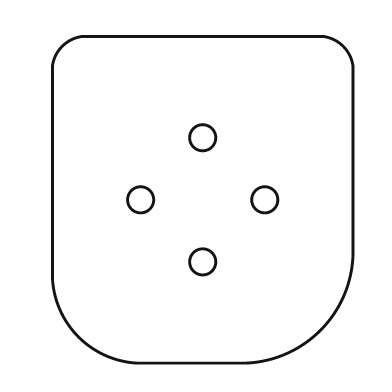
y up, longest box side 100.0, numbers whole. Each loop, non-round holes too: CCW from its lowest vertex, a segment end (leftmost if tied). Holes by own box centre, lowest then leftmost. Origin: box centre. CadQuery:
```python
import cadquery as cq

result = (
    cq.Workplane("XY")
    .moveTo(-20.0, -50.0)
    .lineTo(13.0, -50.0)
    .threePointArc((36.0, -40.0), (46.0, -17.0))
    .lineTo(46.0, 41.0)
    .threePointArc((43.0, 47.0), (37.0, 50.0))
    .lineTo(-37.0, 50.0)
    .threePointArc((-43.0, 47.0), (-46.0, 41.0))
    .lineTo(-46.0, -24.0)
    .threePointArc((-38.0, -42.0), (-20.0, -50.0))
    .close()
    .moveTo(0.0, -19.0)
    .circle(4.0)
    .moveTo(-19.0, 0.0)
    .circle(4.0)
    .moveTo(19.0, 0.0)
    .circle(4.0)
    .moveTo(0.0, 19.0)
    .circle(4.0)
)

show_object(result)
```